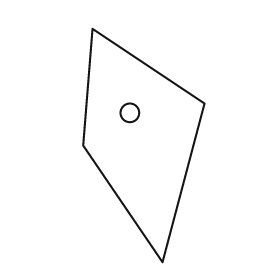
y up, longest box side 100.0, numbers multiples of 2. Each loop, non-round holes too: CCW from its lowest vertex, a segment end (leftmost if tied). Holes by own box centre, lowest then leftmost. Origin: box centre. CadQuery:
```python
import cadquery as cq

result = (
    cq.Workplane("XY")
    .moveTo(8.0, -50.0)
    .lineTo(26.0, 18.0)
    .lineTo(-22.0, 50.0)
    .lineTo(-26.0, 0.0)
    .close()
    .moveTo(-6.0, 14.0)
    .circle(4.0)
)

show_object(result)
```